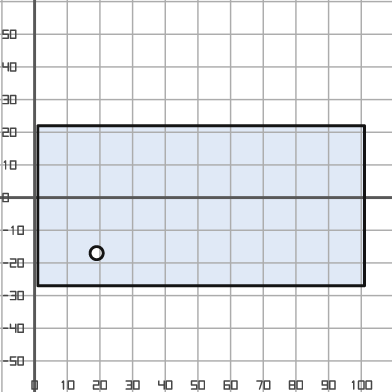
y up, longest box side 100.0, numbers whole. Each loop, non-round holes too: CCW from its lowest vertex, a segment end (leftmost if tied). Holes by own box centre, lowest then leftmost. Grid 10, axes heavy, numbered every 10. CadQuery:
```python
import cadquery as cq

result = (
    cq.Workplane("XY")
    .moveTo(1.0, -27.0)
    .lineTo(101.0, -27.0)
    .lineTo(101.0, 22.0)
    .lineTo(1.0, 22.0)
    .close()
    .moveTo(19.0, -17.0)
    .circle(2.0)
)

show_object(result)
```